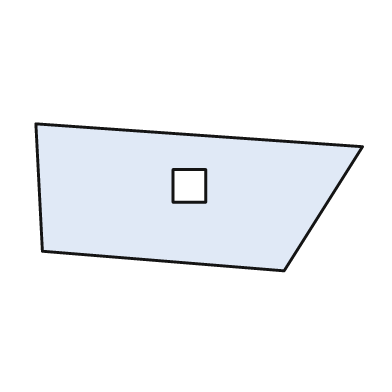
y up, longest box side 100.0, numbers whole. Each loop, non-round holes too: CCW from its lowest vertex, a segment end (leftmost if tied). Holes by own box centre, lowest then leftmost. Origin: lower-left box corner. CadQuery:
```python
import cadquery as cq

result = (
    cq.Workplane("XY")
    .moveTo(76.0, 0.0)
    .lineTo(100.0, 38.0)
    .lineTo(0.0, 45.0)
    .lineTo(2.0, 6.0)
    .close()
    .moveTo(42.0, 21.0)
    .lineTo(52.0, 21.0)
    .lineTo(52.0, 31.0)
    .lineTo(42.0, 31.0)
    .close()
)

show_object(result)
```